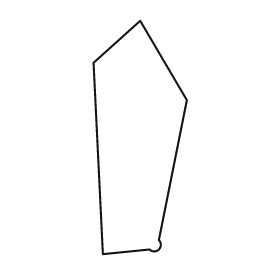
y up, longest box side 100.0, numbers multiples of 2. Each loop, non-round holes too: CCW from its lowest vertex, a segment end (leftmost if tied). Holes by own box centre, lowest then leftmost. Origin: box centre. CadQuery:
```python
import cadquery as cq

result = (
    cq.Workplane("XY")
    .moveTo(-16.0, -50.0)
    .lineTo(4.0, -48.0)
    .threePointArc((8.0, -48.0), (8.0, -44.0))
    .lineTo(20.0, 16.0)
    .lineTo(0.0, 50.0)
    .lineTo(-20.0, 32.0)
    .close()
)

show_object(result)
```